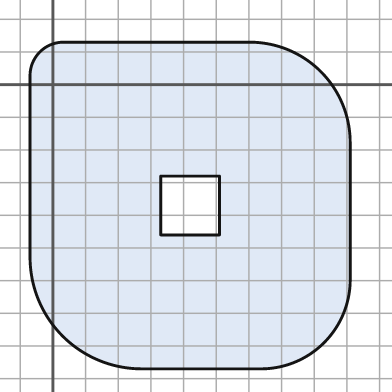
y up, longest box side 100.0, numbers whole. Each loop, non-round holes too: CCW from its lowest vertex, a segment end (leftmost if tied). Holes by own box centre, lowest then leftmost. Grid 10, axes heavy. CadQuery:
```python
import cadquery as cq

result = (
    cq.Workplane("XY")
    .moveTo(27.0, -87.0)
    .lineTo(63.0, -87.0)
    .threePointArc((83.0, -79.0), (91.0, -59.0))
    .lineTo(91.0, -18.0)
    .threePointArc((82.0, 4.0), (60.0, 13.0))
    .lineTo(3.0, 13.0)
    .threePointArc((-4.0, 10.0), (-7.0, 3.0))
    .lineTo(-7.0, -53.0)
    .threePointArc((3.0, -77.0), (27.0, -87.0))
    .close()
    .moveTo(33.0, -46.0)
    .lineTo(51.0, -46.0)
    .lineTo(51.0, -28.0)
    .lineTo(33.0, -28.0)
    .close()
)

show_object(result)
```